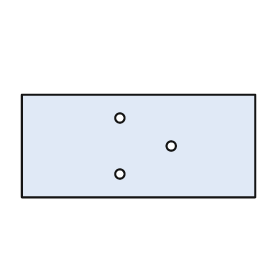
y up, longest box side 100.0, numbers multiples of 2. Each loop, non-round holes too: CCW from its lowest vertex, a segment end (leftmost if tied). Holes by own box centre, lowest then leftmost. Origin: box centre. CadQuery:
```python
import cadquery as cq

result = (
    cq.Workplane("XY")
    .moveTo(-50.0, -22.0)
    .lineTo(50.0, -22.0)
    .lineTo(50.0, 22.0)
    .lineTo(-50.0, 22.0)
    .close()
    .moveTo(-8.0, -12.0)
    .circle(2.0)
    .moveTo(14.0, 0.0)
    .circle(2.0)
    .moveTo(-8.0, 12.0)
    .circle(2.0)
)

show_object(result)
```